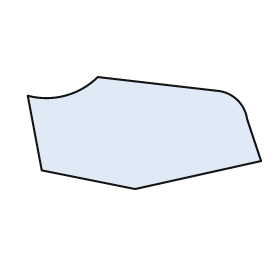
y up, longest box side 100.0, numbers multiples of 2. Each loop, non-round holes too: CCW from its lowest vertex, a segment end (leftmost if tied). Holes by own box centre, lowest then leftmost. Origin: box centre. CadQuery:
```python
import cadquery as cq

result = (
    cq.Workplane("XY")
    .moveTo(-4.0, -24.0)
    .lineTo(50.0, -12.0)
    .lineTo(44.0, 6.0)
    .threePointArc((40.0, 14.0), (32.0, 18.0))
    .lineTo(-20.0, 24.0)
    .threePointArc((-34.0, 16.0), (-50.0, 16.0))
    .lineTo(-44.0, -16.0)
    .close()
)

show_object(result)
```